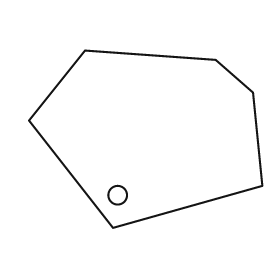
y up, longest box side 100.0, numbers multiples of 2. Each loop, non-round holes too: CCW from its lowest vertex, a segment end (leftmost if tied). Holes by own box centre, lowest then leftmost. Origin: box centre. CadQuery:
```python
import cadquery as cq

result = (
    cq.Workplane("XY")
    .moveTo(-14.0, -38.0)
    .lineTo(50.0, -20.0)
    .lineTo(46.0, 20.0)
    .lineTo(30.0, 34.0)
    .lineTo(-26.0, 38.0)
    .lineTo(-50.0, 8.0)
    .close()
    .moveTo(-12.0, -24.0)
    .circle(4.0)
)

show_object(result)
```